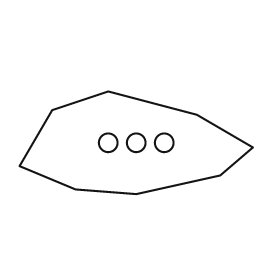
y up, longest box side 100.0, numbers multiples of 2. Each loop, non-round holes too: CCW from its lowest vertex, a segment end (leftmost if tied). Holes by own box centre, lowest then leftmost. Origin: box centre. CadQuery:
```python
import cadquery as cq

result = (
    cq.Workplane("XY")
    .moveTo(0.0, -22.0)
    .lineTo(36.0, -14.0)
    .lineTo(50.0, -2.0)
    .lineTo(26.0, 12.0)
    .lineTo(-12.0, 22.0)
    .lineTo(-36.0, 14.0)
    .lineTo(-50.0, -10.0)
    .lineTo(-26.0, -20.0)
    .close()
    .moveTo(-12.0, 0.0)
    .circle(4.0)
    .moveTo(0.0, 0.0)
    .circle(4.0)
    .moveTo(12.0, 0.0)
    .circle(4.0)
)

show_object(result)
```